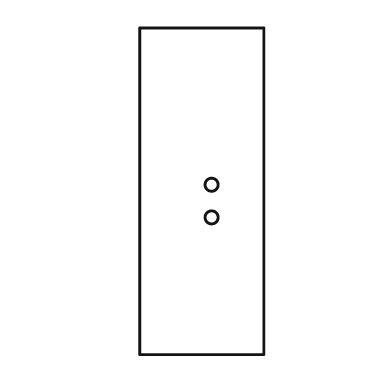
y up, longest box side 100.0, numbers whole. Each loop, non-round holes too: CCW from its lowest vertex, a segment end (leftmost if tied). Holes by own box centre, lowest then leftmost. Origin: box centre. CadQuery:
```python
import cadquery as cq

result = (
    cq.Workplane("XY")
    .moveTo(-19.0, -50.0)
    .lineTo(19.0, -50.0)
    .lineTo(19.0, 50.0)
    .lineTo(-19.0, 50.0)
    .close()
    .moveTo(3.0, -8.0)
    .circle(2.0)
    .moveTo(3.0, 2.0)
    .circle(2.0)
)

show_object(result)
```